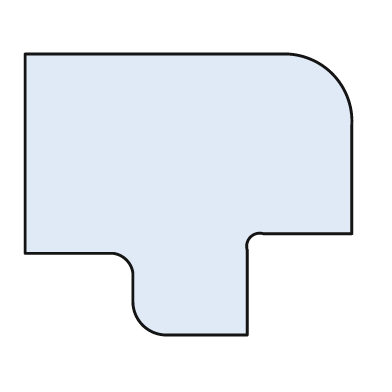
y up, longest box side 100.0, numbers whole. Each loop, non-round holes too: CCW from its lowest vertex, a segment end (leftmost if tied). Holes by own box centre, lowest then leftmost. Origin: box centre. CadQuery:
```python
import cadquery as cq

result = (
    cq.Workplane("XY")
    .moveTo(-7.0, -43.0)
    .lineTo(18.0, -43.0)
    .lineTo(18.0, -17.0)
    .threePointArc((19.0, -13.0), (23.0, -12.0))
    .lineTo(50.0, -12.0)
    .lineTo(50.0, 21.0)
    .threePointArc((44.0, 37.0), (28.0, 43.0))
    .lineTo(-50.0, 43.0)
    .lineTo(-50.0, -18.0)
    .lineTo(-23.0, -18.0)
    .threePointArc((-19.0, -20.0), (-17.0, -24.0))
    .lineTo(-17.0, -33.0)
    .threePointArc((-14.0, -40.0), (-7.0, -43.0))
    .close()
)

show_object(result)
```